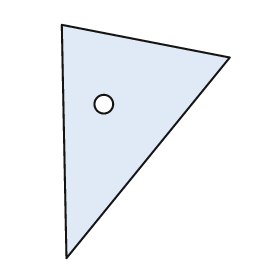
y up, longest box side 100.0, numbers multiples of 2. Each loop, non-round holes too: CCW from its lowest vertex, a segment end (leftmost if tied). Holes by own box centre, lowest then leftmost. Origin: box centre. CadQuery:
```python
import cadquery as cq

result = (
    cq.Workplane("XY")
    .moveTo(-34.0, -50.0)
    .lineTo(36.0, 36.0)
    .lineTo(-36.0, 50.0)
    .close()
    .moveTo(-18.0, 16.0)
    .circle(4.0)
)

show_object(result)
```